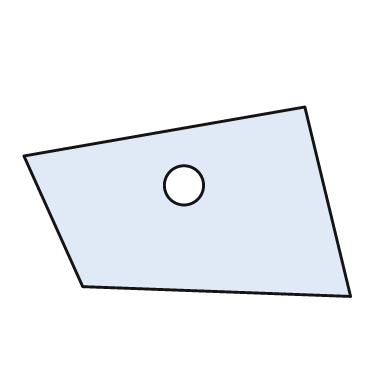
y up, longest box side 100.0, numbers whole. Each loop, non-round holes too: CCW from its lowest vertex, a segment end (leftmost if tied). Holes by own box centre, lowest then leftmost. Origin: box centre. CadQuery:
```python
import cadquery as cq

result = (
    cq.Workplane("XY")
    .moveTo(50.0, -29.0)
    .lineTo(36.0, 29.0)
    .lineTo(-50.0, 14.0)
    .lineTo(-32.0, -26.0)
    .close()
    .moveTo(-1.0, 5.0)
    .circle(6.0)
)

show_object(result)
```